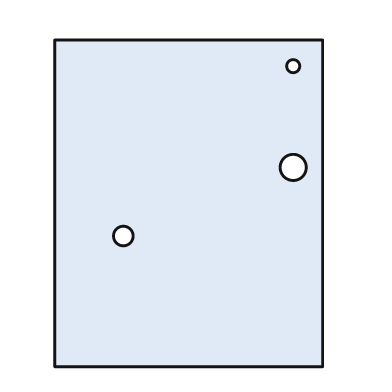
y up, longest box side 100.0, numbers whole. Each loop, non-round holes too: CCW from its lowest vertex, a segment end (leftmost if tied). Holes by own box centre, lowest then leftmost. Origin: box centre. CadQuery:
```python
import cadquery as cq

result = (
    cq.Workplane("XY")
    .moveTo(-41.0, -50.0)
    .lineTo(41.0, -50.0)
    .lineTo(41.0, 50.0)
    .lineTo(-41.0, 50.0)
    .close()
    .moveTo(-20.0, -10.0)
    .circle(3.0)
    .moveTo(32.0, 11.0)
    .circle(4.0)
    .moveTo(32.0, 42.0)
    .circle(2.0)
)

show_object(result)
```